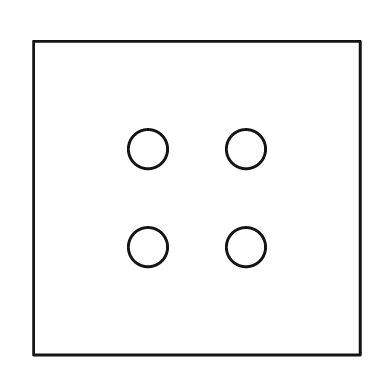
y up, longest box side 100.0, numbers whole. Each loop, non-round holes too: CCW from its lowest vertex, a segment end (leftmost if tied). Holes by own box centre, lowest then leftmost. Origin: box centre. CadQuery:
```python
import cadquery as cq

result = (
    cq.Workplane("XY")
    .moveTo(-50.0, -48.0)
    .lineTo(50.0, -48.0)
    .lineTo(50.0, 48.0)
    .lineTo(-50.0, 48.0)
    .close()
    .moveTo(-15.0, -15.0)
    .circle(6.0)
    .moveTo(15.0, -15.0)
    .circle(6.0)
    .moveTo(-15.0, 15.0)
    .circle(6.0)
    .moveTo(15.0, 15.0)
    .circle(6.0)
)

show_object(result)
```